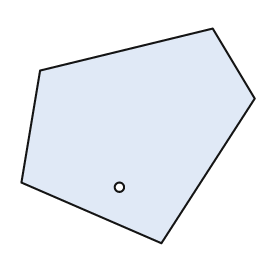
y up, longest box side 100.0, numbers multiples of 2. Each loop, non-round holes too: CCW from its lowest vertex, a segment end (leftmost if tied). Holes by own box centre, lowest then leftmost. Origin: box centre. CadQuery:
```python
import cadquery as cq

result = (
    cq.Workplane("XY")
    .moveTo(10.0, -46.0)
    .lineTo(50.0, 16.0)
    .lineTo(32.0, 46.0)
    .lineTo(-42.0, 28.0)
    .lineTo(-50.0, -20.0)
    .close()
    .moveTo(-8.0, -22.0)
    .circle(2.0)
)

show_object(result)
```